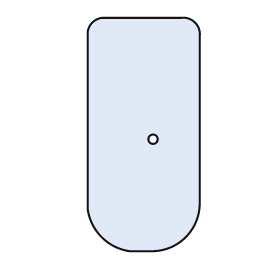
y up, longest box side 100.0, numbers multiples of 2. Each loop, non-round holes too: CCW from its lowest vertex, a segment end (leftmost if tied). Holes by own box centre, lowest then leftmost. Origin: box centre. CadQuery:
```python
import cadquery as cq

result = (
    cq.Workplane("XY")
    .moveTo(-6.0, -50.0)
    .lineTo(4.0, -50.0)
    .threePointArc((18.0, -44.0), (24.0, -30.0))
    .lineTo(24.0, 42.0)
    .threePointArc((22.0, 48.0), (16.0, 50.0))
    .lineTo(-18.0, 50.0)
    .threePointArc((-22.0, 48.0), (-24.0, 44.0))
    .lineTo(-24.0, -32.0)
    .threePointArc((-18.0, -44.0), (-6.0, -50.0))
    .close()
    .moveTo(4.0, -2.0)
    .circle(2.0)
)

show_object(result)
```